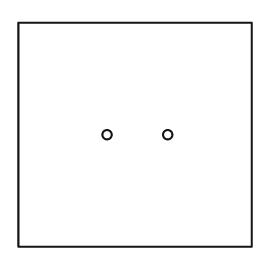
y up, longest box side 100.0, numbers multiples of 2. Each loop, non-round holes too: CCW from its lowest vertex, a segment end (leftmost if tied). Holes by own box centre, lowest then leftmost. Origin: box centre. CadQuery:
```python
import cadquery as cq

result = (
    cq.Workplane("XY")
    .moveTo(-50.0, -48.0)
    .lineTo(50.0, -48.0)
    .lineTo(50.0, 48.0)
    .lineTo(-50.0, 48.0)
    .close()
    .moveTo(-12.0, 0.0)
    .circle(2.0)
    .moveTo(14.0, 0.0)
    .circle(2.0)
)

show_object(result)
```